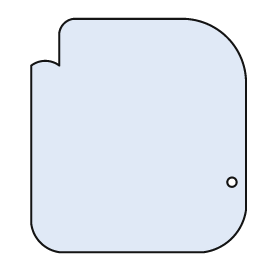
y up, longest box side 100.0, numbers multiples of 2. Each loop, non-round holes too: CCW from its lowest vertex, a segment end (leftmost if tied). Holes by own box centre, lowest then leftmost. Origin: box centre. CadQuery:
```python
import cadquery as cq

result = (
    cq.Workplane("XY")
    .moveTo(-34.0, -50.0)
    .lineTo(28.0, -50.0)
    .threePointArc((40.0, -44.0), (46.0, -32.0))
    .lineTo(46.0, 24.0)
    .threePointArc((38.0, 42.0), (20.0, 50.0))
    .lineTo(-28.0, 50.0)
    .threePointArc((-32.0, 48.0), (-34.0, 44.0))
    .lineTo(-34.0, 30.0)
    .threePointArc((-40.0, 32.0), (-46.0, 30.0))
    .lineTo(-46.0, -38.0)
    .threePointArc((-42.0, -46.0), (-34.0, -50.0))
    .close()
    .moveTo(40.0, -20.0)
    .circle(2.0)
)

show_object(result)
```